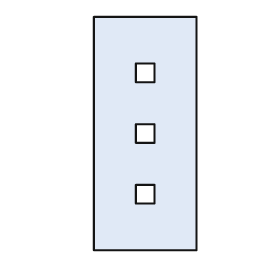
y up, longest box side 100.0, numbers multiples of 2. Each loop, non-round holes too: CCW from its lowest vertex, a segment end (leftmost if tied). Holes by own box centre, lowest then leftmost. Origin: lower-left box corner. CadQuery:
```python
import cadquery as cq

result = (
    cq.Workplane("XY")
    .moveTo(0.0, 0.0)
    .lineTo(44.0, 0.0)
    .lineTo(44.0, 100.0)
    .lineTo(0.0, 100.0)
    .close()
    .moveTo(18.0, 20.0)
    .lineTo(26.0, 20.0)
    .lineTo(26.0, 28.0)
    .lineTo(18.0, 28.0)
    .close()
    .moveTo(18.0, 46.0)
    .lineTo(26.0, 46.0)
    .lineTo(26.0, 54.0)
    .lineTo(18.0, 54.0)
    .close()
    .moveTo(18.0, 72.0)
    .lineTo(26.0, 72.0)
    .lineTo(26.0, 80.0)
    .lineTo(18.0, 80.0)
    .close()
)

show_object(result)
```